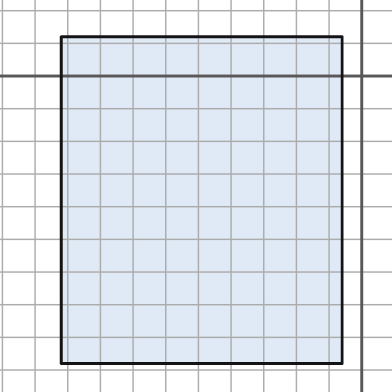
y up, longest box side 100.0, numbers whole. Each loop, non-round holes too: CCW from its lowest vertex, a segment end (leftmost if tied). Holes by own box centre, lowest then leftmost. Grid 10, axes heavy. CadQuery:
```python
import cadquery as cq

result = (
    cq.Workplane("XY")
    .moveTo(-92.0, -88.0)
    .lineTo(-6.0, -88.0)
    .lineTo(-6.0, 12.0)
    .lineTo(-92.0, 12.0)
    .close()
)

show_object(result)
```